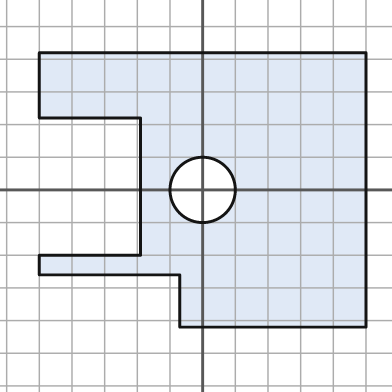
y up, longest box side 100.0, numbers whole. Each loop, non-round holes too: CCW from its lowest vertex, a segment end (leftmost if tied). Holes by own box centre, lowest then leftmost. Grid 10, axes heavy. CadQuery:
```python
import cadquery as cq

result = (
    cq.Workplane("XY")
    .moveTo(-7.0, -42.0)
    .lineTo(50.0, -42.0)
    .lineTo(50.0, 42.0)
    .lineTo(-50.0, 42.0)
    .lineTo(-50.0, 22.0)
    .lineTo(-19.0, 22.0)
    .lineTo(-19.0, -20.0)
    .lineTo(-50.0, -20.0)
    .lineTo(-50.0, -26.0)
    .lineTo(-7.0, -26.0)
    .close()
    .moveTo(0.0, 0.0)
    .circle(10.0)
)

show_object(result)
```